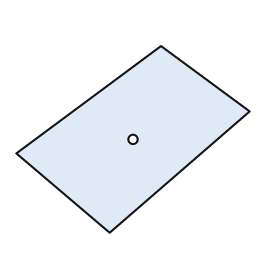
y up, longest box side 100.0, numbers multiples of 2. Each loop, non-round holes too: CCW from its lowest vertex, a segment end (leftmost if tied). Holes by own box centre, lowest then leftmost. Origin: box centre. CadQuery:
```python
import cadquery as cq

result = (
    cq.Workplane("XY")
    .moveTo(-10.0, -40.0)
    .lineTo(50.0, 12.0)
    .lineTo(12.0, 40.0)
    .lineTo(-50.0, -6.0)
    .close()
    .moveTo(0.0, 0.0)
    .circle(2.0)
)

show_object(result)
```